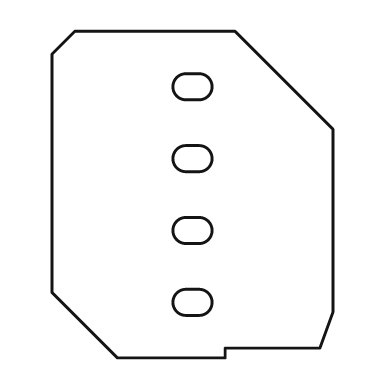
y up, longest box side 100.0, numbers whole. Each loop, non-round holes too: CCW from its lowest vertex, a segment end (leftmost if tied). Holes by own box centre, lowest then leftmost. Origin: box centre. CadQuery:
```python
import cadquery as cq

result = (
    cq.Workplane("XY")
    .moveTo(-23.0, -50.0)
    .lineTo(10.0, -50.0)
    .lineTo(10.0, -47.0)
    .lineTo(39.0, -47.0)
    .lineTo(43.0, -36.0)
    .lineTo(43.0, 20.0)
    .lineTo(13.0, 50.0)
    .lineTo(-36.0, 50.0)
    .lineTo(-43.0, 43.0)
    .lineTo(-43.0, -30.0)
    .close()
    .moveTo(-2.0, -37.0)
    .lineTo(2.0, -37.0)
    .threePointArc((6.0, -33.0), (2.0, -29.0))
    .lineTo(-2.0, -29.0)
    .threePointArc((-6.0, -33.0), (-2.0, -37.0))
    .close()
    .moveTo(-2.0, -15.0)
    .lineTo(2.0, -15.0)
    .threePointArc((6.0, -11.0), (2.0, -7.0))
    .lineTo(-2.0, -7.0)
    .threePointArc((-6.0, -11.0), (-2.0, -15.0))
    .close()
    .moveTo(-2.0, 7.0)
    .lineTo(2.0, 7.0)
    .threePointArc((6.0, 11.0), (2.0, 15.0))
    .lineTo(-2.0, 15.0)
    .threePointArc((-6.0, 11.0), (-2.0, 7.0))
    .close()
    .moveTo(-2.0, 29.0)
    .lineTo(2.0, 29.0)
    .threePointArc((6.0, 33.0), (2.0, 37.0))
    .lineTo(-2.0, 37.0)
    .threePointArc((-6.0, 33.0), (-2.0, 29.0))
    .close()
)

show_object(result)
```